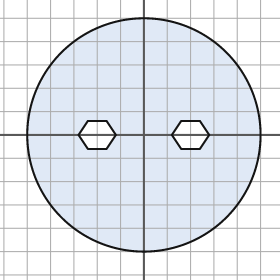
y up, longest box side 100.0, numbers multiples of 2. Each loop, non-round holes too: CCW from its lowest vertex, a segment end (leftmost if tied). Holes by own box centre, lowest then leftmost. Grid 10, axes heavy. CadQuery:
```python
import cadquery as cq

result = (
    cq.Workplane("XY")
    .moveTo(0.0, 0.0)
    .circle(50.0)
    .moveTo(-24.0, -6.0)
    .lineTo(-16.0, -6.0)
    .lineTo(-12.0, 0.0)
    .lineTo(-16.0, 6.0)
    .lineTo(-24.0, 6.0)
    .lineTo(-28.0, 0.0)
    .close()
    .moveTo(16.0, -6.0)
    .lineTo(24.0, -6.0)
    .lineTo(28.0, 0.0)
    .lineTo(24.0, 6.0)
    .lineTo(16.0, 6.0)
    .lineTo(12.0, 0.0)
    .close()
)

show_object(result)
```